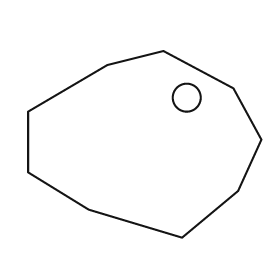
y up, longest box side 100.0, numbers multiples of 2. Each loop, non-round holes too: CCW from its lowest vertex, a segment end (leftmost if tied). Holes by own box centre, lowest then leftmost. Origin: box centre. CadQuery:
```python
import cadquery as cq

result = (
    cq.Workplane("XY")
    .moveTo(16.0, -40.0)
    .lineTo(40.0, -20.0)
    .lineTo(50.0, 2.0)
    .lineTo(38.0, 24.0)
    .lineTo(8.0, 40.0)
    .lineTo(-16.0, 34.0)
    .lineTo(-50.0, 14.0)
    .lineTo(-50.0, -12.0)
    .lineTo(-24.0, -28.0)
    .close()
    .moveTo(18.0, 20.0)
    .circle(6.0)
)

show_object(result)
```